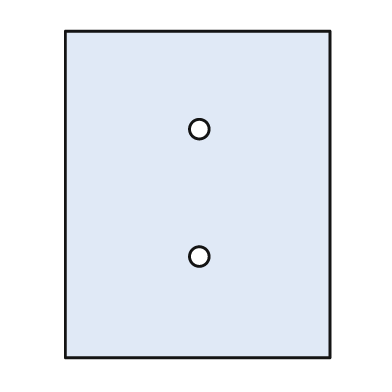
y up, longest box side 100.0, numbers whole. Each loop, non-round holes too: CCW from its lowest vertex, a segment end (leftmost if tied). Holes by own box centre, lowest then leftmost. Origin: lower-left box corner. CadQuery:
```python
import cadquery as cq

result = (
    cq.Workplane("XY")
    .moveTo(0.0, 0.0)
    .lineTo(81.0, 0.0)
    .lineTo(81.0, 100.0)
    .lineTo(0.0, 100.0)
    .close()
    .moveTo(41.0, 31.0)
    .circle(3.0)
    .moveTo(41.0, 70.0)
    .circle(3.0)
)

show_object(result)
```